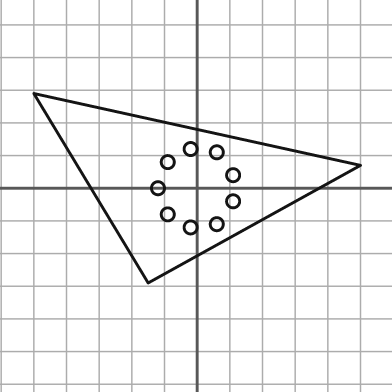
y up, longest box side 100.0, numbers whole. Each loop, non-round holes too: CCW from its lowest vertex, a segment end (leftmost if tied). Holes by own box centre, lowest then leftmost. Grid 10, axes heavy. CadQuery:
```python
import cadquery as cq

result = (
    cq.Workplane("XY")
    .moveTo(-15.0, -29.0)
    .lineTo(50.0, 7.0)
    .lineTo(-50.0, 29.0)
    .close()
    .moveTo(-2.0, -12.0)
    .circle(2.0)
    .moveTo(6.0, -11.0)
    .circle(2.0)
    .moveTo(-9.0, -8.0)
    .circle(2.0)
    .moveTo(11.0, -4.0)
    .circle(2.0)
    .moveTo(-12.0, 0.0)
    .circle(2.0)
    .moveTo(11.0, 4.0)
    .circle(2.0)
    .moveTo(-9.0, 8.0)
    .circle(2.0)
    .moveTo(6.0, 11.0)
    .circle(2.0)
    .moveTo(-2.0, 12.0)
    .circle(2.0)
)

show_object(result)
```